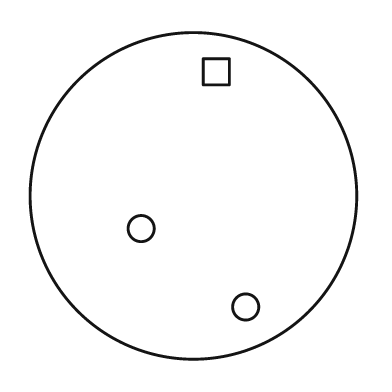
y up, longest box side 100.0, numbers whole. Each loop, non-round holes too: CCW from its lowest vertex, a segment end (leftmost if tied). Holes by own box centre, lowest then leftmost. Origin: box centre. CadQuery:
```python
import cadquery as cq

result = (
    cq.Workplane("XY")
    .moveTo(0.0, 0.0)
    .circle(50.0)
    .moveTo(16.0, -34.0)
    .circle(4.0)
    .moveTo(-16.0, -10.0)
    .circle(4.0)
    .moveTo(3.0, 34.0)
    .lineTo(11.0, 34.0)
    .lineTo(11.0, 42.0)
    .lineTo(3.0, 42.0)
    .close()
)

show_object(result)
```